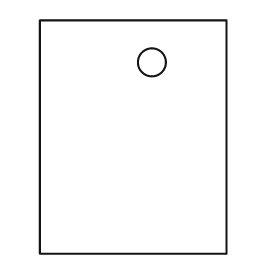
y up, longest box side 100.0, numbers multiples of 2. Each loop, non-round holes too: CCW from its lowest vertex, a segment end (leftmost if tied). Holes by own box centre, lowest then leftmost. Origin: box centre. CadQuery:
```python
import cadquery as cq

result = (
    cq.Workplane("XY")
    .moveTo(-40.0, -50.0)
    .lineTo(40.0, -50.0)
    .lineTo(40.0, 50.0)
    .lineTo(-40.0, 50.0)
    .close()
    .moveTo(8.0, 32.0)
    .circle(6.0)
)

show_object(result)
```